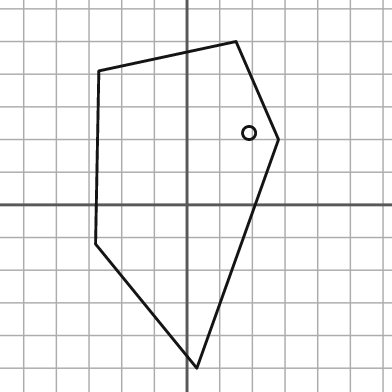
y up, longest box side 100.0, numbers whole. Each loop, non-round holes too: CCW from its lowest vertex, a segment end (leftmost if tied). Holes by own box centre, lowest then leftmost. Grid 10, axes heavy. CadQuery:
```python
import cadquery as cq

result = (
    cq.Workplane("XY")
    .moveTo(3.0, -50.0)
    .lineTo(28.0, 20.0)
    .lineTo(15.0, 50.0)
    .lineTo(-27.0, 41.0)
    .lineTo(-28.0, -12.0)
    .close()
    .moveTo(19.0, 22.0)
    .circle(2.0)
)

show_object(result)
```